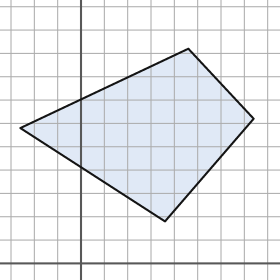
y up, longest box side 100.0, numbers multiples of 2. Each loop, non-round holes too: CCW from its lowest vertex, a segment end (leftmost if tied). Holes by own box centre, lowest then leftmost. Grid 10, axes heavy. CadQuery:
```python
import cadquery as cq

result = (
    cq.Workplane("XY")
    .moveTo(36.0, 18.0)
    .lineTo(74.0, 62.0)
    .lineTo(46.0, 92.0)
    .lineTo(-26.0, 58.0)
    .close()
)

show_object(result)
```